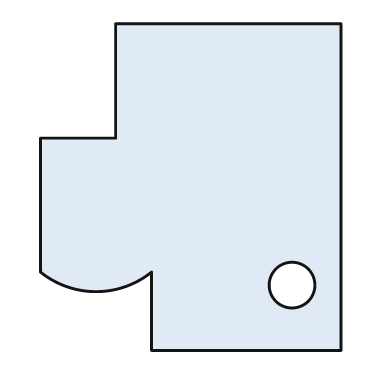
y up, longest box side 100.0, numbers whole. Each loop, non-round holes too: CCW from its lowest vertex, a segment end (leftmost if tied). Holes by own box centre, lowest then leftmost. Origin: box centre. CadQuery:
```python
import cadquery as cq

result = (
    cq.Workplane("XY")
    .moveTo(-12.0, -50.0)
    .lineTo(46.0, -50.0)
    .lineTo(46.0, 50.0)
    .lineTo(-23.0, 50.0)
    .lineTo(-23.0, 15.0)
    .lineTo(-46.0, 15.0)
    .lineTo(-46.0, -26.0)
    .threePointArc((-29.0, -32.0), (-12.0, -26.0))
    .close()
    .moveTo(31.0, -30.0)
    .circle(7.0)
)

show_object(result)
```